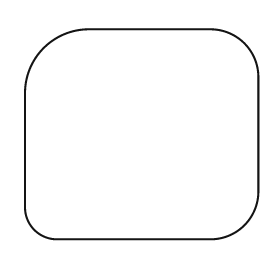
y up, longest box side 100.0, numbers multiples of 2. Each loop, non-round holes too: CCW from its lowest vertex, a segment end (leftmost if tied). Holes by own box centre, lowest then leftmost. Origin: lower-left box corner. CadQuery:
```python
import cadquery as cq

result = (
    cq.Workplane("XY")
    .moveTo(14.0, 0.0)
    .lineTo(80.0, 0.0)
    .threePointArc((94.0, 6.0), (100.0, 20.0))
    .lineTo(100.0, 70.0)
    .threePointArc((94.0, 84.0), (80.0, 90.0))
    .lineTo(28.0, 90.0)
    .threePointArc((8.0, 82.0), (0.0, 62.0))
    .lineTo(0.0, 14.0)
    .threePointArc((4.0, 4.0), (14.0, 0.0))
    .close()
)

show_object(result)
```